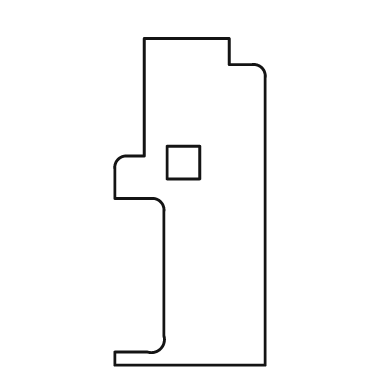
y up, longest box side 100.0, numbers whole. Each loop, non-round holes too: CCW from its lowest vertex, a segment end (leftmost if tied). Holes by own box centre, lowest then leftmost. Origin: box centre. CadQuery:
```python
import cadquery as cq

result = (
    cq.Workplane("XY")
    .moveTo(-23.0, -50.0)
    .lineTo(23.0, -50.0)
    .lineTo(23.0, 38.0)
    .threePointArc((22.0, 41.0), (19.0, 42.0))
    .lineTo(12.0, 42.0)
    .lineTo(12.0, 50.0)
    .lineTo(-14.0, 50.0)
    .lineTo(-14.0, 14.0)
    .lineTo(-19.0, 14.0)
    .threePointArc((-22.0, 13.0), (-23.0, 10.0))
    .lineTo(-23.0, 1.0)
    .lineTo(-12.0, 1.0)
    .threePointArc((-9.0, 0.0), (-8.0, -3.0))
    .lineTo(-8.0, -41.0)
    .threePointArc((-9.0, -45.0), (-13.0, -46.0))
    .lineTo(-23.0, -46.0)
    .close()
    .moveTo(-7.0, 7.0)
    .lineTo(3.0, 7.0)
    .lineTo(3.0, 17.0)
    .lineTo(-7.0, 17.0)
    .close()
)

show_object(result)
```